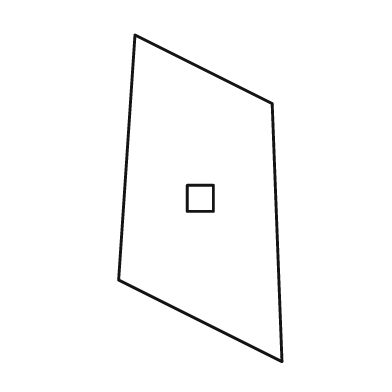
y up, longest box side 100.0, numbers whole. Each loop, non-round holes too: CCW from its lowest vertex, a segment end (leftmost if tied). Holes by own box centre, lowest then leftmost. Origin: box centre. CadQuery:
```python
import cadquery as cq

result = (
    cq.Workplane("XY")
    .moveTo(25.0, -50.0)
    .lineTo(22.0, 29.0)
    .lineTo(-20.0, 50.0)
    .lineTo(-25.0, -25.0)
    .close()
    .moveTo(-4.0, -4.0)
    .lineTo(4.0, -4.0)
    .lineTo(4.0, 4.0)
    .lineTo(-4.0, 4.0)
    .close()
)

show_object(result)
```